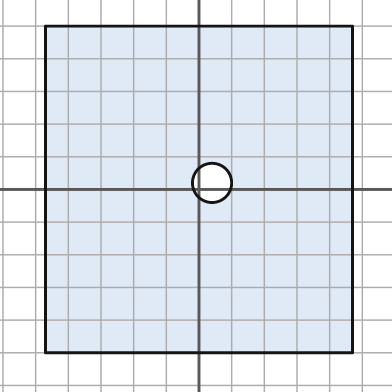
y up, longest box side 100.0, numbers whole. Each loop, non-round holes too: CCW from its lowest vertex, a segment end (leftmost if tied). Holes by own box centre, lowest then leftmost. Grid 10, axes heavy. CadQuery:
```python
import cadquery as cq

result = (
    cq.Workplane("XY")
    .moveTo(-47.0, -50.0)
    .lineTo(47.0, -50.0)
    .lineTo(47.0, 50.0)
    .lineTo(-47.0, 50.0)
    .close()
    .moveTo(4.0, 2.0)
    .circle(6.0)
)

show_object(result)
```